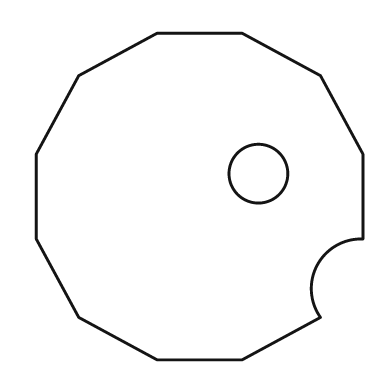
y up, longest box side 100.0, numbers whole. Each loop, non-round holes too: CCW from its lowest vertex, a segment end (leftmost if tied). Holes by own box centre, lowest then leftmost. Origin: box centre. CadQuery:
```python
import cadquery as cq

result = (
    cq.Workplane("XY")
    .moveTo(-13.0, -50.0)
    .lineTo(13.0, -50.0)
    .lineTo(37.0, -37.0)
    .threePointArc((36.0, -21.0), (50.0, -13.0))
    .lineTo(50.0, 13.0)
    .lineTo(37.0, 37.0)
    .lineTo(13.0, 50.0)
    .lineTo(-13.0, 50.0)
    .lineTo(-37.0, 37.0)
    .lineTo(-50.0, 13.0)
    .lineTo(-50.0, -13.0)
    .lineTo(-37.0, -37.0)
    .close()
    .moveTo(18.0, 7.0)
    .circle(9.0)
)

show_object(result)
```